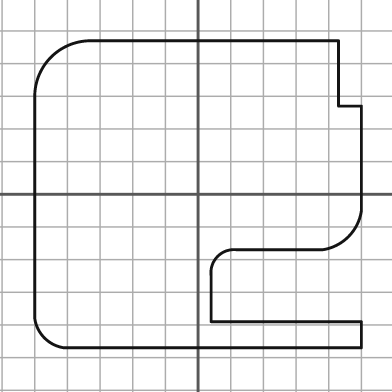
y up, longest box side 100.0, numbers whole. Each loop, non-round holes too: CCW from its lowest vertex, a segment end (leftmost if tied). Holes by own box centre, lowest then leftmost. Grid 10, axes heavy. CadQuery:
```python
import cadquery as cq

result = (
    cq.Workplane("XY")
    .moveTo(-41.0, -47.0)
    .lineTo(50.0, -47.0)
    .lineTo(50.0, -39.0)
    .lineTo(4.0, -39.0)
    .lineTo(4.0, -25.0)
    .threePointArc((6.0, -19.0), (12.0, -17.0))
    .lineTo(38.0, -17.0)
    .threePointArc((46.0, -13.0), (50.0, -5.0))
    .lineTo(50.0, 27.0)
    .lineTo(43.0, 27.0)
    .lineTo(43.0, 47.0)
    .lineTo(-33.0, 47.0)
    .threePointArc((-45.0, 42.0), (-50.0, 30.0))
    .lineTo(-50.0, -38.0)
    .threePointArc((-47.0, -44.0), (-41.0, -47.0))
    .close()
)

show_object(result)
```